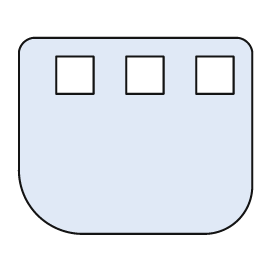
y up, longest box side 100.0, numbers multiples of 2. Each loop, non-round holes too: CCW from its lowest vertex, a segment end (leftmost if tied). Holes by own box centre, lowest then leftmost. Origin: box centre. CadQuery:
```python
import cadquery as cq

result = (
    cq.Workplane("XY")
    .moveTo(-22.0, -42.0)
    .lineTo(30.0, -42.0)
    .threePointArc((44.0, -36.0), (50.0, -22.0))
    .lineTo(50.0, 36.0)
    .threePointArc((48.0, 40.0), (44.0, 42.0))
    .lineTo(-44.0, 42.0)
    .threePointArc((-48.0, 40.0), (-50.0, 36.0))
    .lineTo(-50.0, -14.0)
    .threePointArc((-42.0, -34.0), (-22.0, -42.0))
    .close()
    .moveTo(-34.0, 18.0)
    .lineTo(-18.0, 18.0)
    .lineTo(-18.0, 34.0)
    .lineTo(-34.0, 34.0)
    .close()
    .moveTo(-4.0, 18.0)
    .lineTo(12.0, 18.0)
    .lineTo(12.0, 34.0)
    .lineTo(-4.0, 34.0)
    .close()
    .moveTo(26.0, 18.0)
    .lineTo(42.0, 18.0)
    .lineTo(42.0, 34.0)
    .lineTo(26.0, 34.0)
    .close()
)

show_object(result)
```